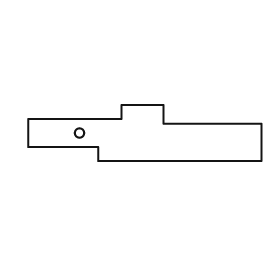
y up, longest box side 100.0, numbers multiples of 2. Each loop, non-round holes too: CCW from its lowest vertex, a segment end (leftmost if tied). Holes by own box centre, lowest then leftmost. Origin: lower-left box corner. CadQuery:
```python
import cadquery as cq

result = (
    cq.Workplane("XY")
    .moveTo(30.0, 0.0)
    .lineTo(100.0, 0.0)
    .lineTo(100.0, 16.0)
    .lineTo(58.0, 16.0)
    .lineTo(58.0, 24.0)
    .lineTo(40.0, 24.0)
    .lineTo(40.0, 18.0)
    .lineTo(0.0, 18.0)
    .lineTo(0.0, 6.0)
    .lineTo(30.0, 6.0)
    .close()
    .moveTo(22.0, 12.0)
    .circle(2.0)
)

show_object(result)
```